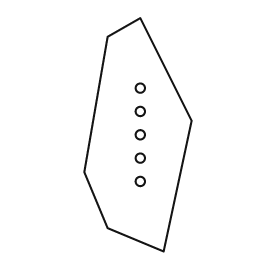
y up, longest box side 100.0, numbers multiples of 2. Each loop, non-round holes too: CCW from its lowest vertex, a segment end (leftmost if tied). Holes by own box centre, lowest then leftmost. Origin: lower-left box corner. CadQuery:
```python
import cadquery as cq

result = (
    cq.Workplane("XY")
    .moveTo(34.0, 0.0)
    .lineTo(46.0, 56.0)
    .lineTo(24.0, 100.0)
    .lineTo(10.0, 92.0)
    .lineTo(0.0, 34.0)
    .lineTo(10.0, 10.0)
    .close()
    .moveTo(24.0, 30.0)
    .circle(2.0)
    .moveTo(24.0, 40.0)
    .circle(2.0)
    .moveTo(24.0, 50.0)
    .circle(2.0)
    .moveTo(24.0, 60.0)
    .circle(2.0)
    .moveTo(24.0, 70.0)
    .circle(2.0)
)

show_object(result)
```